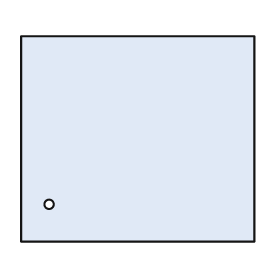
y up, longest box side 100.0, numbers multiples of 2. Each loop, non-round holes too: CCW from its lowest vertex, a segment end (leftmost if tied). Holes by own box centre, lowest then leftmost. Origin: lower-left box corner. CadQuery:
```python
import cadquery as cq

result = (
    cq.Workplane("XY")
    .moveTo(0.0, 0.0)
    .lineTo(100.0, 0.0)
    .lineTo(100.0, 88.0)
    .lineTo(0.0, 88.0)
    .close()
    .moveTo(12.0, 16.0)
    .circle(2.0)
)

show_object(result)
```